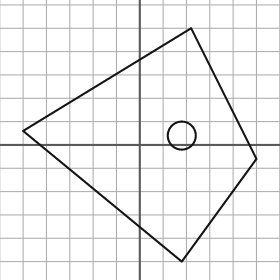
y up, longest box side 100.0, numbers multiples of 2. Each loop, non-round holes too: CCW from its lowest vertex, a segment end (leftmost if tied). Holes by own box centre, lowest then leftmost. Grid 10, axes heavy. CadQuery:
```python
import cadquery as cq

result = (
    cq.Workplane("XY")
    .moveTo(18.0, -50.0)
    .lineTo(50.0, -6.0)
    .lineTo(22.0, 50.0)
    .lineTo(-50.0, 6.0)
    .close()
    .moveTo(18.0, 4.0)
    .circle(6.0)
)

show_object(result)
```